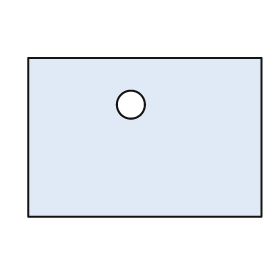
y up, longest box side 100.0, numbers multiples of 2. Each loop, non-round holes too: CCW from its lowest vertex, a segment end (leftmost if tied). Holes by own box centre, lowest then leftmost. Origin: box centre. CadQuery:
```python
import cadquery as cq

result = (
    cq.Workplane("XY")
    .moveTo(-50.0, -34.0)
    .lineTo(50.0, -34.0)
    .lineTo(50.0, 34.0)
    .lineTo(-50.0, 34.0)
    .close()
    .moveTo(-6.0, 14.0)
    .circle(6.0)
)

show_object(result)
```